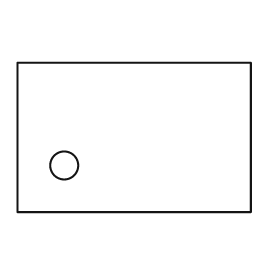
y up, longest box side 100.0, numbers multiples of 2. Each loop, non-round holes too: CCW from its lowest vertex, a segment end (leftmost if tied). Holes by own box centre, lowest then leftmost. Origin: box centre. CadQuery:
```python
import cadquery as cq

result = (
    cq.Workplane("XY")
    .moveTo(-50.0, -32.0)
    .lineTo(50.0, -32.0)
    .lineTo(50.0, 32.0)
    .lineTo(-50.0, 32.0)
    .close()
    .moveTo(-30.0, -12.0)
    .circle(6.0)
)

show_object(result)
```